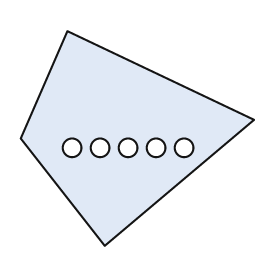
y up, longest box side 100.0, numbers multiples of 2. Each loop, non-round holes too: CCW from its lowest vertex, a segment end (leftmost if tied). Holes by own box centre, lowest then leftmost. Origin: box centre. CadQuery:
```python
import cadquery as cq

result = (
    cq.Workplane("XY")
    .moveTo(-14.0, -46.0)
    .lineTo(50.0, 8.0)
    .lineTo(-30.0, 46.0)
    .lineTo(-50.0, 0.0)
    .close()
    .moveTo(-28.0, -4.0)
    .circle(4.0)
    .moveTo(-16.0, -4.0)
    .circle(4.0)
    .moveTo(-4.0, -4.0)
    .circle(4.0)
    .moveTo(8.0, -4.0)
    .circle(4.0)
    .moveTo(20.0, -4.0)
    .circle(4.0)
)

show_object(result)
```